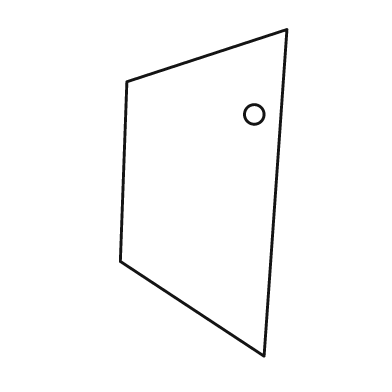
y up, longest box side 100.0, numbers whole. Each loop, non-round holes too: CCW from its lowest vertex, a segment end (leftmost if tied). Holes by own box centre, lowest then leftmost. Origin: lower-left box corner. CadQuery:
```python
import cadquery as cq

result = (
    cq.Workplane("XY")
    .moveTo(44.0, 0.0)
    .lineTo(51.0, 100.0)
    .lineTo(2.0, 84.0)
    .lineTo(0.0, 29.0)
    .close()
    .moveTo(41.0, 74.0)
    .circle(3.0)
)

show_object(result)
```